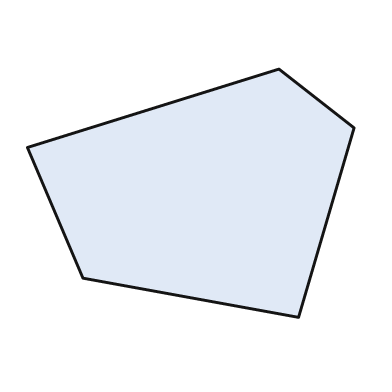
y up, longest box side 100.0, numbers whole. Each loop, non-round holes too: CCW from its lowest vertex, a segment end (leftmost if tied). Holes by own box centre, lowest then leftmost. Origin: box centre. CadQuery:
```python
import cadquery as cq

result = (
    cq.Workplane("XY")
    .moveTo(33.0, -38.0)
    .lineTo(50.0, 20.0)
    .lineTo(27.0, 38.0)
    .lineTo(-50.0, 14.0)
    .lineTo(-33.0, -26.0)
    .close()
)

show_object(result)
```